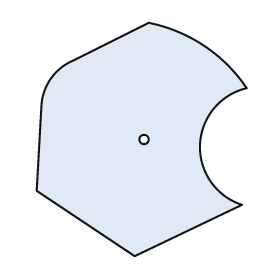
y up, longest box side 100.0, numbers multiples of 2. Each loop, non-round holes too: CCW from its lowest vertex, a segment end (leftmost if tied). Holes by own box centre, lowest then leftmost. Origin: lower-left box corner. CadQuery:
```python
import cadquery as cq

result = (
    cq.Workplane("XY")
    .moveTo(42.0, 0.0)
    .lineTo(88.0, 22.0)
    .threePointArc((70.0, 48.0), (90.0, 72.0))
    .threePointArc((72.0, 90.0), (48.0, 100.0))
    .lineTo(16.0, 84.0)
    .threePointArc((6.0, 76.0), (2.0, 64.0))
    .lineTo(0.0, 28.0)
    .close()
    .moveTo(46.0, 50.0)
    .circle(2.0)
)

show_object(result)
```